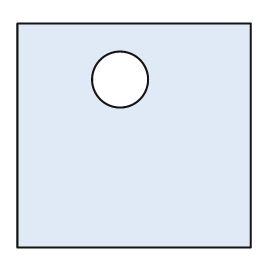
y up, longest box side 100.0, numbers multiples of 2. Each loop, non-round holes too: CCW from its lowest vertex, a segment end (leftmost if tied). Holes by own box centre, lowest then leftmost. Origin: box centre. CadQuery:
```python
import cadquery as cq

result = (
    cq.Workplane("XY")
    .moveTo(-50.0, -48.0)
    .lineTo(50.0, -48.0)
    .lineTo(50.0, 48.0)
    .lineTo(-50.0, 48.0)
    .close()
    .moveTo(-6.0, 24.0)
    .circle(12.0)
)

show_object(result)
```